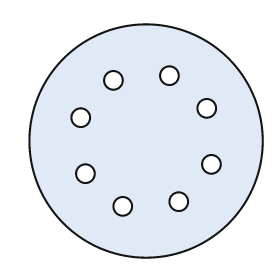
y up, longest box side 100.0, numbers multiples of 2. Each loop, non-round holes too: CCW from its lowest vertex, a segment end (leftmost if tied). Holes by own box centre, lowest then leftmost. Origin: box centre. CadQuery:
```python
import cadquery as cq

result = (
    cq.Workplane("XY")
    .moveTo(0.0, 0.0)
    .circle(50.0)
    .moveTo(-10.0, -28.0)
    .circle(4.0)
    .moveTo(14.0, -26.0)
    .circle(4.0)
    .moveTo(-26.0, -14.0)
    .circle(4.0)
    .moveTo(28.0, -10.0)
    .circle(4.0)
    .moveTo(-28.0, 10.0)
    .circle(4.0)
    .moveTo(26.0, 14.0)
    .circle(4.0)
    .moveTo(-14.0, 26.0)
    .circle(4.0)
    .moveTo(10.0, 28.0)
    .circle(4.0)
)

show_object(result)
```